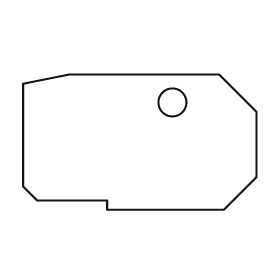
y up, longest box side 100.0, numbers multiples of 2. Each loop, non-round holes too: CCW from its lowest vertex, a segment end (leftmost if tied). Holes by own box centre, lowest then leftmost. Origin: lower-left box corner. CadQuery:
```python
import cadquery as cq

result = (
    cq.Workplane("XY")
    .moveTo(36.0, 0.0)
    .lineTo(86.0, 0.0)
    .lineTo(100.0, 14.0)
    .lineTo(100.0, 42.0)
    .lineTo(84.0, 58.0)
    .lineTo(20.0, 58.0)
    .lineTo(0.0, 54.0)
    .lineTo(0.0, 10.0)
    .lineTo(6.0, 4.0)
    .lineTo(36.0, 4.0)
    .close()
    .moveTo(64.0, 46.0)
    .circle(6.0)
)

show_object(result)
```